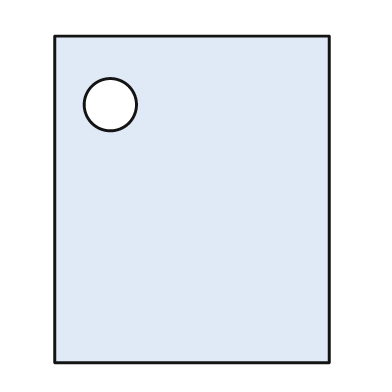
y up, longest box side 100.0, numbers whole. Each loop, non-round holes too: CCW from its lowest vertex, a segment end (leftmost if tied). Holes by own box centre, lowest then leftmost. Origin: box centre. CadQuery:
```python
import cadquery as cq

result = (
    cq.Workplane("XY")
    .moveTo(-42.0, -50.0)
    .lineTo(42.0, -50.0)
    .lineTo(42.0, 50.0)
    .lineTo(-42.0, 50.0)
    .close()
    .moveTo(-25.0, 29.0)
    .circle(8.0)
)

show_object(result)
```